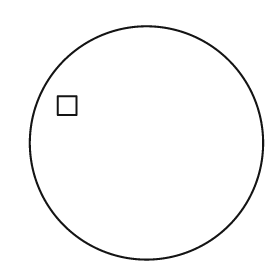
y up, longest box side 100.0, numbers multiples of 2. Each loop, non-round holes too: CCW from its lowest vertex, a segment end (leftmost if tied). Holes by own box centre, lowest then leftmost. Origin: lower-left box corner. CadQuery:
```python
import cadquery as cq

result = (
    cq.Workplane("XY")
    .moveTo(50.0, 50.0)
    .circle(50.0)
    .moveTo(12.0, 62.0)
    .lineTo(20.0, 62.0)
    .lineTo(20.0, 70.0)
    .lineTo(12.0, 70.0)
    .close()
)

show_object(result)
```